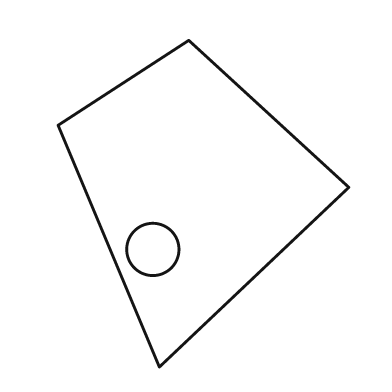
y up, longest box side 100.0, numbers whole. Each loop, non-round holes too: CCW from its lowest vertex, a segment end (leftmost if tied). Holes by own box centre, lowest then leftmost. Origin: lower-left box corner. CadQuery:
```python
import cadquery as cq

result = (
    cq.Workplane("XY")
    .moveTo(31.0, 0.0)
    .lineTo(89.0, 55.0)
    .lineTo(40.0, 100.0)
    .lineTo(0.0, 74.0)
    .close()
    .moveTo(29.0, 36.0)
    .circle(8.0)
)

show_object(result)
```